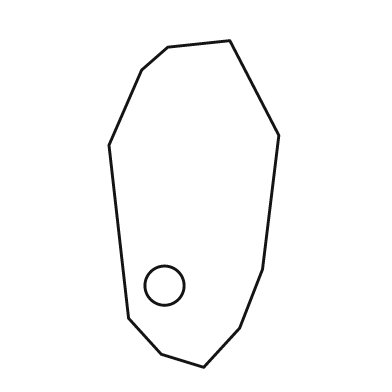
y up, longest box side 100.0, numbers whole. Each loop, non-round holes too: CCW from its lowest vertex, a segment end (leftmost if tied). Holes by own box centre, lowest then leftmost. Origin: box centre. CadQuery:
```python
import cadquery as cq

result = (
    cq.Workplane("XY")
    .moveTo(3.0, -50.0)
    .lineTo(14.0, -38.0)
    .lineTo(21.0, -20.0)
    .lineTo(26.0, 21.0)
    .lineTo(11.0, 50.0)
    .lineTo(-8.0, 48.0)
    .lineTo(-16.0, 41.0)
    .lineTo(-26.0, 18.0)
    .lineTo(-20.0, -35.0)
    .lineTo(-10.0, -46.0)
    .close()
    .moveTo(-9.0, -25.0)
    .circle(6.0)
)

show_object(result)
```